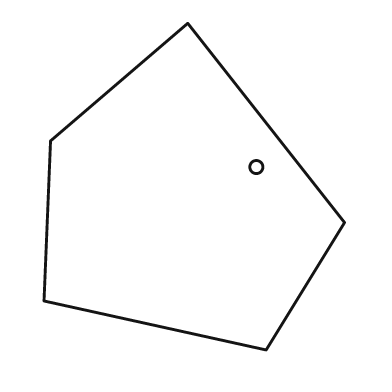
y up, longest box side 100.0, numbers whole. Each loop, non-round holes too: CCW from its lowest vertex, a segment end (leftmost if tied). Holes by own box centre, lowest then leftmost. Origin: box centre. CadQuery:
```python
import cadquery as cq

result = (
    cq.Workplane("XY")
    .moveTo(22.0, -50.0)
    .lineTo(46.0, -11.0)
    .lineTo(-2.0, 50.0)
    .lineTo(-44.0, 14.0)
    .lineTo(-46.0, -35.0)
    .close()
    .moveTo(19.0, 6.0)
    .circle(2.0)
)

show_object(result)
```